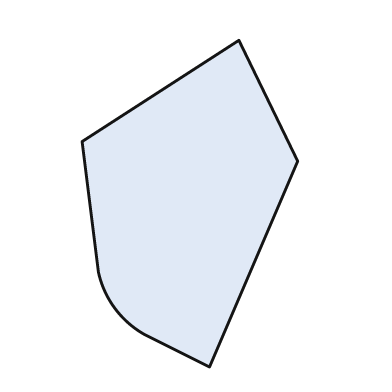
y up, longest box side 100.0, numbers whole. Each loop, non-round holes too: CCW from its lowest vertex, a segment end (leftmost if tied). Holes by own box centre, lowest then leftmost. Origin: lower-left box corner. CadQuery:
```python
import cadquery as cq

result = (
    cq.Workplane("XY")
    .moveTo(39.0, 0.0)
    .lineTo(66.0, 63.0)
    .lineTo(48.0, 100.0)
    .lineTo(0.0, 69.0)
    .lineTo(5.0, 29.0)
    .threePointArc((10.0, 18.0), (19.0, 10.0))
    .close()
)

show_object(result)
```